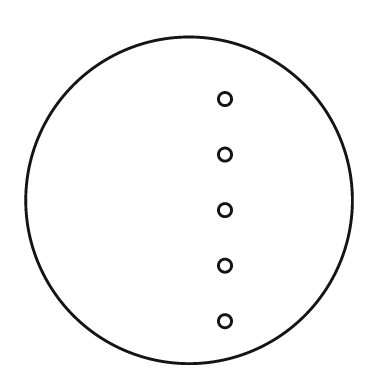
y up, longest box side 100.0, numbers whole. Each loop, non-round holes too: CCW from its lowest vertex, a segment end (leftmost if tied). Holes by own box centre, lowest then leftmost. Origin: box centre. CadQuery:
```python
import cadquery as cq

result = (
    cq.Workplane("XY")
    .moveTo(0.0, 0.0)
    .circle(50.0)
    .moveTo(11.0, -37.0)
    .circle(2.0)
    .moveTo(11.0, -20.0)
    .circle(2.0)
    .moveTo(11.0, -3.0)
    .circle(2.0)
    .moveTo(11.0, 14.0)
    .circle(2.0)
    .moveTo(11.0, 31.0)
    .circle(2.0)
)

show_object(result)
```